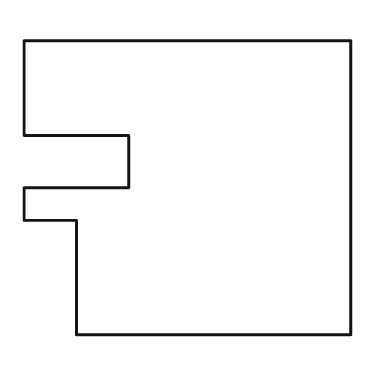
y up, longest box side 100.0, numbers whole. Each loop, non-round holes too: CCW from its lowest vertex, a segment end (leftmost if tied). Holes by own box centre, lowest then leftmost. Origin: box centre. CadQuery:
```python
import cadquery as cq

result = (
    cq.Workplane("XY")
    .moveTo(-34.0, -45.0)
    .lineTo(50.0, -45.0)
    .lineTo(50.0, 45.0)
    .lineTo(-50.0, 45.0)
    .lineTo(-50.0, 16.0)
    .lineTo(-18.0, 16.0)
    .lineTo(-18.0, 0.0)
    .lineTo(-50.0, 0.0)
    .lineTo(-50.0, -10.0)
    .lineTo(-34.0, -10.0)
    .close()
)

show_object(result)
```